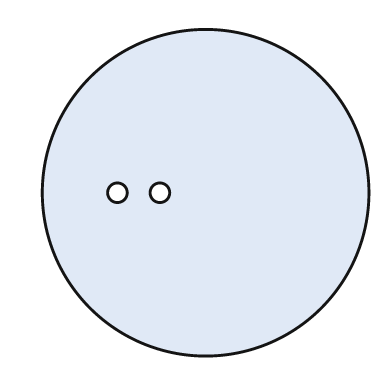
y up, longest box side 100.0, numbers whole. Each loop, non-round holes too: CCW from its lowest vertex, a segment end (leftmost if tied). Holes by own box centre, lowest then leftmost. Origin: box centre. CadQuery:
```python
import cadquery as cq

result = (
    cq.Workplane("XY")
    .moveTo(0.0, 0.0)
    .circle(50.0)
    .moveTo(-27.0, 0.0)
    .circle(3.0)
    .moveTo(-14.0, 0.0)
    .circle(3.0)
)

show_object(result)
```